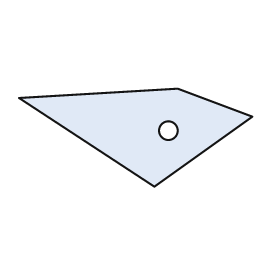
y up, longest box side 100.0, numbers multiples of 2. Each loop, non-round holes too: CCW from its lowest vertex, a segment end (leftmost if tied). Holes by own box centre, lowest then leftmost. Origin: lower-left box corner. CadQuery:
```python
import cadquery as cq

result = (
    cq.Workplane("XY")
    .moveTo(58.0, 0.0)
    .lineTo(100.0, 30.0)
    .lineTo(68.0, 42.0)
    .lineTo(0.0, 38.0)
    .close()
    .moveTo(64.0, 24.0)
    .circle(4.0)
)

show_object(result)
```